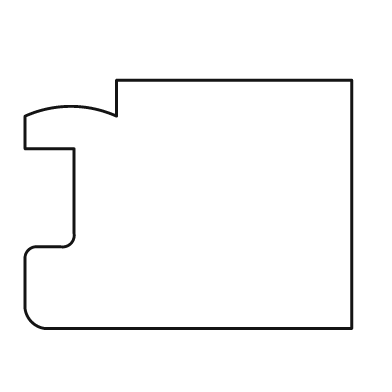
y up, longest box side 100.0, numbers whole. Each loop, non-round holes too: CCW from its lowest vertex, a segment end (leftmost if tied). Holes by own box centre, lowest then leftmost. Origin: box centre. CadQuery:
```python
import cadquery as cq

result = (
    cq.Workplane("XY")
    .moveTo(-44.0, -38.0)
    .lineTo(50.0, -38.0)
    .lineTo(50.0, 38.0)
    .lineTo(-22.0, 38.0)
    .lineTo(-22.0, 27.0)
    .threePointArc((-36.0, 30.0), (-50.0, 27.0))
    .lineTo(-50.0, 17.0)
    .lineTo(-35.0, 17.0)
    .lineTo(-35.0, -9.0)
    .threePointArc((-36.0, -12.0), (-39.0, -13.0))
    .lineTo(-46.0, -13.0)
    .threePointArc((-49.0, -14.0), (-50.0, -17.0))
    .lineTo(-50.0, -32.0)
    .threePointArc((-48.0, -36.0), (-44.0, -38.0))
    .close()
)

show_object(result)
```